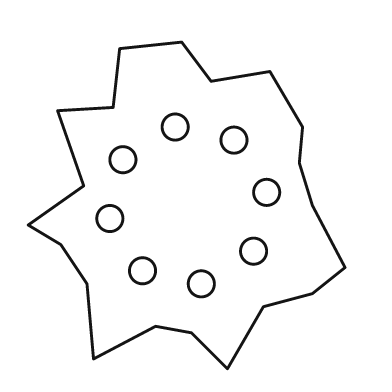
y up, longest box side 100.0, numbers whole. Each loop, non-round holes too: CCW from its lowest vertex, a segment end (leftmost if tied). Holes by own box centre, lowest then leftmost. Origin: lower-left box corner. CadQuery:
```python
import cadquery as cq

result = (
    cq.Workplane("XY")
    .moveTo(61.0, 0.0)
    .lineTo(72.0, 19.0)
    .lineTo(87.0, 23.0)
    .lineTo(97.0, 31.0)
    .lineTo(87.0, 50.0)
    .lineTo(83.0, 63.0)
    .lineTo(84.0, 74.0)
    .lineTo(74.0, 91.0)
    .lineTo(56.0, 88.0)
    .lineTo(47.0, 100.0)
    .lineTo(28.0, 98.0)
    .lineTo(26.0, 80.0)
    .lineTo(9.0, 79.0)
    .lineTo(17.0, 56.0)
    .lineTo(0.0, 44.0)
    .lineTo(10.0, 38.0)
    .lineTo(18.0, 26.0)
    .lineTo(20.0, 3.0)
    .lineTo(39.0, 13.0)
    .lineTo(50.0, 11.0)
    .close()
    .moveTo(53.0, 26.0)
    .circle(4.0)
    .moveTo(35.0, 30.0)
    .circle(4.0)
    .moveTo(69.0, 36.0)
    .circle(4.0)
    .moveTo(25.0, 46.0)
    .circle(4.0)
    .moveTo(73.0, 54.0)
    .circle(4.0)
    .moveTo(29.0, 64.0)
    .circle(4.0)
    .moveTo(63.0, 70.0)
    .circle(4.0)
    .moveTo(45.0, 74.0)
    .circle(4.0)
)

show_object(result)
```